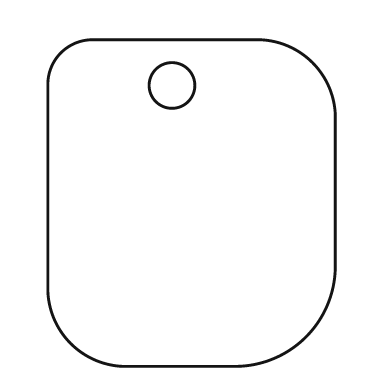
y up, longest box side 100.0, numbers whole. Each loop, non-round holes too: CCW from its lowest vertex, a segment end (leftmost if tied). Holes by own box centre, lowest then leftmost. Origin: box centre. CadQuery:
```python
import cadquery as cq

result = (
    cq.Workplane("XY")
    .moveTo(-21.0, -50.0)
    .lineTo(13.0, -50.0)
    .threePointArc((35.0, -41.0), (44.0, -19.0))
    .lineTo(44.0, 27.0)
    .threePointArc((37.0, 43.0), (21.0, 50.0))
    .lineTo(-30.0, 50.0)
    .threePointArc((-40.0, 46.0), (-44.0, 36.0))
    .lineTo(-44.0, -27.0)
    .threePointArc((-37.0, -43.0), (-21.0, -50.0))
    .close()
    .moveTo(-6.0, 36.0)
    .circle(7.0)
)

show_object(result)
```